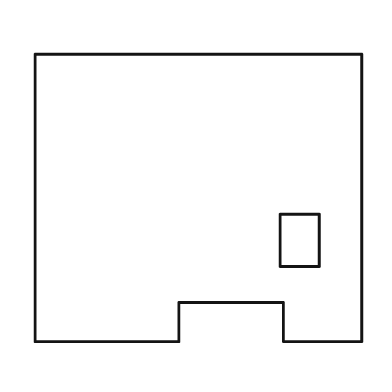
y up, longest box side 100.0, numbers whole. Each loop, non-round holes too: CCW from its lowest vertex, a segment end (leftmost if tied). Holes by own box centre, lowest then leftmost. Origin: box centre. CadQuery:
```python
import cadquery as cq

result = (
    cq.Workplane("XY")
    .moveTo(-50.0, -44.0)
    .lineTo(-6.0, -44.0)
    .lineTo(-6.0, -32.0)
    .lineTo(26.0, -32.0)
    .lineTo(26.0, -44.0)
    .lineTo(50.0, -44.0)
    .lineTo(50.0, 44.0)
    .lineTo(-50.0, 44.0)
    .close()
    .moveTo(25.0, -21.0)
    .lineTo(37.0, -21.0)
    .lineTo(37.0, -5.0)
    .lineTo(25.0, -5.0)
    .close()
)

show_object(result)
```